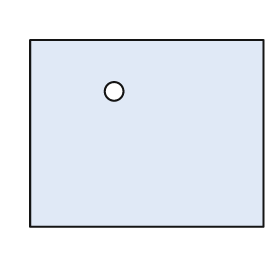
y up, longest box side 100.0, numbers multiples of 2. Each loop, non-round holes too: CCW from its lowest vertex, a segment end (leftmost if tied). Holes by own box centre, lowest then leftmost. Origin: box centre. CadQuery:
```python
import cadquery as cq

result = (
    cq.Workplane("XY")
    .moveTo(-50.0, -40.0)
    .lineTo(50.0, -40.0)
    .lineTo(50.0, 40.0)
    .lineTo(-50.0, 40.0)
    .close()
    .moveTo(-14.0, 18.0)
    .circle(4.0)
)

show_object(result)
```